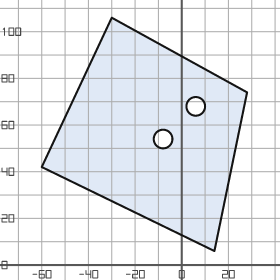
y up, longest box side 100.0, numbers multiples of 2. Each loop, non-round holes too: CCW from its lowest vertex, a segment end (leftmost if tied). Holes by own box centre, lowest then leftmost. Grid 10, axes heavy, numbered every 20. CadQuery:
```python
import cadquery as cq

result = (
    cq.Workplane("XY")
    .moveTo(14.0, 6.0)
    .lineTo(28.0, 74.0)
    .lineTo(-30.0, 106.0)
    .lineTo(-60.0, 42.0)
    .close()
    .moveTo(-8.0, 54.0)
    .circle(4.0)
    .moveTo(6.0, 68.0)
    .circle(4.0)
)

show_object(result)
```